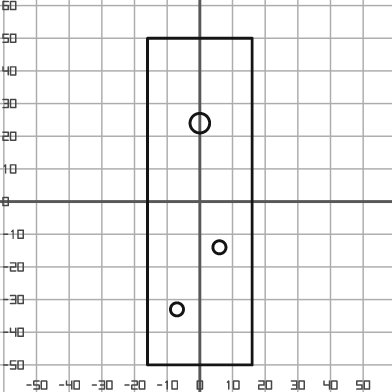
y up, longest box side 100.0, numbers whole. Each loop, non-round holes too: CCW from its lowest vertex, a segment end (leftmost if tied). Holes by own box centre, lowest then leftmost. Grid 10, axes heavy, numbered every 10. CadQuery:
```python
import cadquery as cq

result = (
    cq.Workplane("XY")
    .moveTo(-16.0, -50.0)
    .lineTo(16.0, -50.0)
    .lineTo(16.0, 50.0)
    .lineTo(-16.0, 50.0)
    .close()
    .moveTo(-7.0, -33.0)
    .circle(2.0)
    .moveTo(6.0, -14.0)
    .circle(2.0)
    .moveTo(0.0, 24.0)
    .circle(3.0)
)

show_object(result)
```